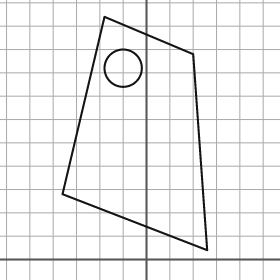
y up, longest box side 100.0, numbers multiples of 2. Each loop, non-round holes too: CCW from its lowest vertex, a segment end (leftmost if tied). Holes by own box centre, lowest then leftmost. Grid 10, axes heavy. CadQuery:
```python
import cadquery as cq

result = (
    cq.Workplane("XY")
    .moveTo(26.0, 4.0)
    .lineTo(20.0, 88.0)
    .lineTo(-18.0, 104.0)
    .lineTo(-36.0, 28.0)
    .close()
    .moveTo(-10.0, 82.0)
    .circle(8.0)
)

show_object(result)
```